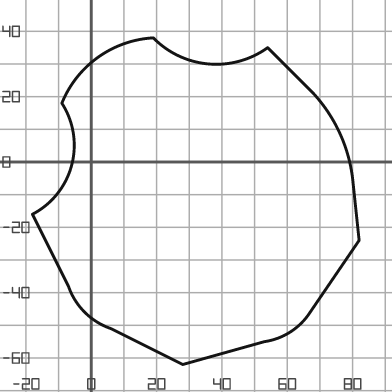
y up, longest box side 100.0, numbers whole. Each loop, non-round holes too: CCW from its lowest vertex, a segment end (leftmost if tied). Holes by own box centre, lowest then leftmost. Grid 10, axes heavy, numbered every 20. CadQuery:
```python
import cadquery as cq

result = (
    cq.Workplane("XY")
    .moveTo(28.0, -62.0)
    .lineTo(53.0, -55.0)
    .threePointArc((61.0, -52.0), (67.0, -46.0))
    .lineTo(82.0, -24.0)
    .lineTo(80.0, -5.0)
    .threePointArc((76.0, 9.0), (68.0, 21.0))
    .lineTo(54.0, 35.0)
    .threePointArc((36.0, 30.0), (19.0, 38.0))
    .threePointArc((2.0, 32.0), (-9.0, 18.0))
    .threePointArc((-6.0, -1.0), (-18.0, -16.0))
    .lineTo(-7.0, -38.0)
    .threePointArc((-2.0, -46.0), (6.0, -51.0))
    .close()
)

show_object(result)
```